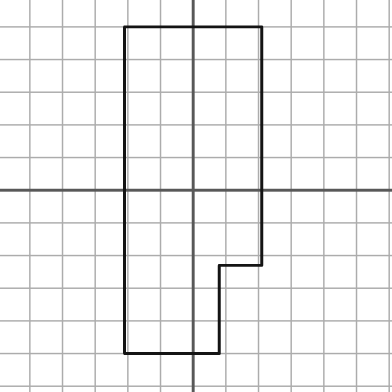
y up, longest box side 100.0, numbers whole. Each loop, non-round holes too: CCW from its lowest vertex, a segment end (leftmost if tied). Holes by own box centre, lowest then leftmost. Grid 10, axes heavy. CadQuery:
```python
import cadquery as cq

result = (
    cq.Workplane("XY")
    .moveTo(-21.0, -50.0)
    .lineTo(8.0, -50.0)
    .lineTo(8.0, -23.0)
    .lineTo(21.0, -23.0)
    .lineTo(21.0, 50.0)
    .lineTo(-21.0, 50.0)
    .close()
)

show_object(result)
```